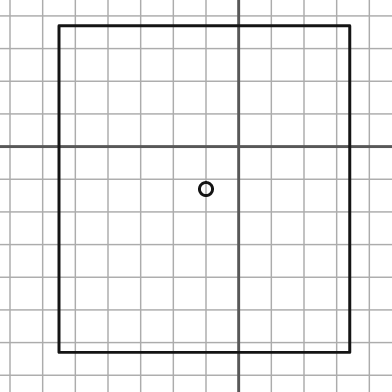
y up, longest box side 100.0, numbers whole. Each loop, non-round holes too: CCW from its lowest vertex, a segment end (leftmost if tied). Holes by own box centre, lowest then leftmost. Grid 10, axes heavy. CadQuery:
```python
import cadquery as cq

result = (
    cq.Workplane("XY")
    .moveTo(-55.0, -63.0)
    .lineTo(34.0, -63.0)
    .lineTo(34.0, 37.0)
    .lineTo(-55.0, 37.0)
    .close()
    .moveTo(-10.0, -13.0)
    .circle(2.0)
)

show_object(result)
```